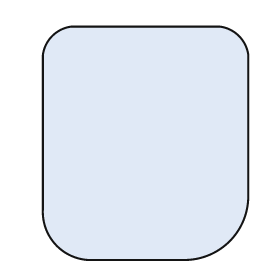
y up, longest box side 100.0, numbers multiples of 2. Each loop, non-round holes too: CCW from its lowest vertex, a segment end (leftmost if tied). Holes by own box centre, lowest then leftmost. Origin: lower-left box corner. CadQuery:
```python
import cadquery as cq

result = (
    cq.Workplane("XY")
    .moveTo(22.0, 0.0)
    .lineTo(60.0, 0.0)
    .threePointArc((80.0, 8.0), (88.0, 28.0))
    .lineTo(88.0, 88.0)
    .threePointArc((84.0, 96.0), (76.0, 100.0))
    .lineTo(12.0, 100.0)
    .threePointArc((4.0, 96.0), (0.0, 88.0))
    .lineTo(0.0, 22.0)
    .threePointArc((6.0, 6.0), (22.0, 0.0))
    .close()
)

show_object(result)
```